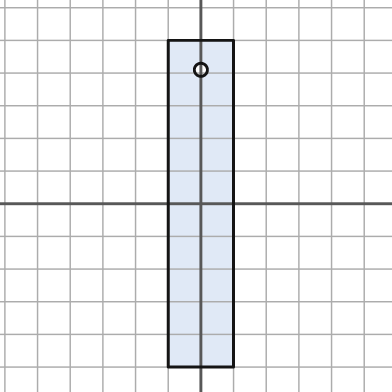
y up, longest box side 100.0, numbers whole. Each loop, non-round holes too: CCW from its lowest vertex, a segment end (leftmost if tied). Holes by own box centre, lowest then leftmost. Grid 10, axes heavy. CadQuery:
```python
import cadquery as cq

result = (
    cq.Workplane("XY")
    .moveTo(-10.0, -50.0)
    .lineTo(10.0, -50.0)
    .lineTo(10.0, 50.0)
    .lineTo(-10.0, 50.0)
    .close()
    .moveTo(0.0, 41.0)
    .circle(2.0)
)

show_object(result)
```